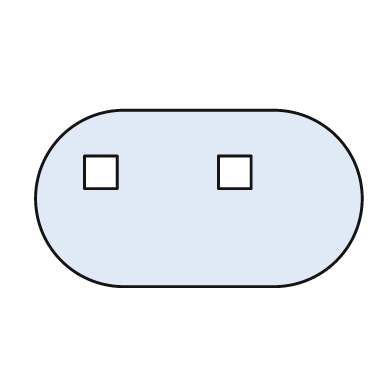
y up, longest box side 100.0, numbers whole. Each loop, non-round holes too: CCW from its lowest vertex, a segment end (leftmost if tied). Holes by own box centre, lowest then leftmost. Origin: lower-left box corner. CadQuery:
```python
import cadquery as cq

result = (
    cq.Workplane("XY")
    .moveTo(27.0, 0.0)
    .lineTo(73.0, 0.0)
    .threePointArc((100.0, 27.0), (73.0, 54.0))
    .lineTo(27.0, 54.0)
    .threePointArc((0.0, 27.0), (27.0, 0.0))
    .close()
    .moveTo(15.0, 30.0)
    .lineTo(25.0, 30.0)
    .lineTo(25.0, 40.0)
    .lineTo(15.0, 40.0)
    .close()
    .moveTo(56.0, 30.0)
    .lineTo(66.0, 30.0)
    .lineTo(66.0, 40.0)
    .lineTo(56.0, 40.0)
    .close()
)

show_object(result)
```